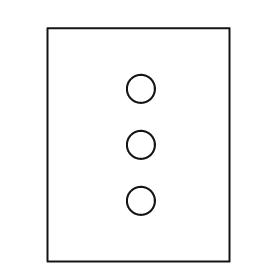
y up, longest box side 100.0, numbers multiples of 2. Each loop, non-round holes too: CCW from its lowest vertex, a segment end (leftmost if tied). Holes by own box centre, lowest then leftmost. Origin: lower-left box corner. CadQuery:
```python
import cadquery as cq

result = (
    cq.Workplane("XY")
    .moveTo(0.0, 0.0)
    .lineTo(78.0, 0.0)
    .lineTo(78.0, 100.0)
    .lineTo(0.0, 100.0)
    .close()
    .moveTo(40.0, 26.0)
    .circle(6.0)
    .moveTo(40.0, 50.0)
    .circle(6.0)
    .moveTo(40.0, 74.0)
    .circle(6.0)
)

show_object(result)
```